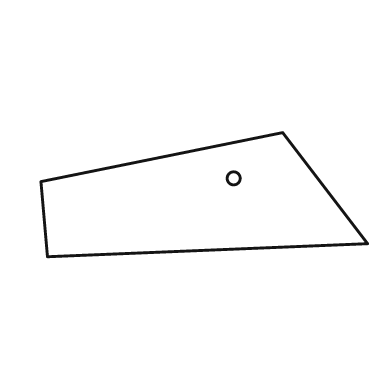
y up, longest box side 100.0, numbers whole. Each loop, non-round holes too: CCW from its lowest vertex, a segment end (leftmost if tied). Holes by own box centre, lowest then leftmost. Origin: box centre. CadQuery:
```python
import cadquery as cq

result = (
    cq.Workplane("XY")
    .moveTo(-48.0, -19.0)
    .lineTo(50.0, -15.0)
    .lineTo(24.0, 19.0)
    .lineTo(-50.0, 4.0)
    .close()
    .moveTo(9.0, 5.0)
    .circle(2.0)
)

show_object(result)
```